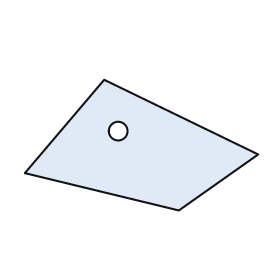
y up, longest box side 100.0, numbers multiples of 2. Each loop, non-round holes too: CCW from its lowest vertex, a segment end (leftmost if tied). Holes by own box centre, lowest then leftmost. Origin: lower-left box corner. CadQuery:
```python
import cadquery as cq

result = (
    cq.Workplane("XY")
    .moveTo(66.0, 0.0)
    .lineTo(100.0, 24.0)
    .lineTo(34.0, 56.0)
    .lineTo(0.0, 16.0)
    .close()
    .moveTo(40.0, 34.0)
    .circle(4.0)
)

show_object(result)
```